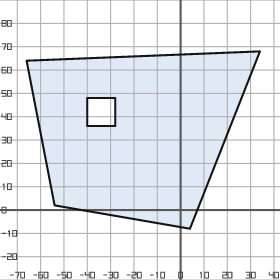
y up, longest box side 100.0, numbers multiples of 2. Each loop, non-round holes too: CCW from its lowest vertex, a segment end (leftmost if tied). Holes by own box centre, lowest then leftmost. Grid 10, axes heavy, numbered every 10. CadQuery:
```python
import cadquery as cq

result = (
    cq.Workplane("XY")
    .moveTo(4.0, -8.0)
    .lineTo(34.0, 68.0)
    .lineTo(-66.0, 64.0)
    .lineTo(-54.0, 2.0)
    .close()
    .moveTo(-40.0, 36.0)
    .lineTo(-28.0, 36.0)
    .lineTo(-28.0, 48.0)
    .lineTo(-40.0, 48.0)
    .close()
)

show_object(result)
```